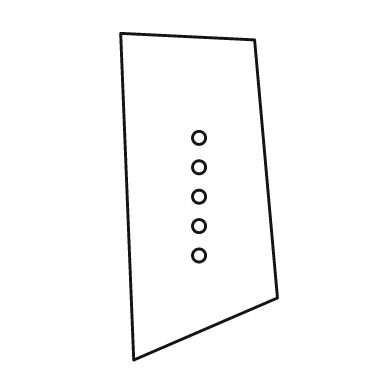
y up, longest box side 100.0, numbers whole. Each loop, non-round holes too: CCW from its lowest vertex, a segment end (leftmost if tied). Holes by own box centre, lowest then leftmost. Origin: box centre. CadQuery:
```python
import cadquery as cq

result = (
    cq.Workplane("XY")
    .moveTo(-20.0, -50.0)
    .lineTo(24.0, -31.0)
    .lineTo(17.0, 48.0)
    .lineTo(-24.0, 50.0)
    .close()
    .moveTo(0.0, -18.0)
    .circle(2.0)
    .moveTo(0.0, -9.0)
    .circle(2.0)
    .moveTo(0.0, 0.0)
    .circle(2.0)
    .moveTo(0.0, 9.0)
    .circle(2.0)
    .moveTo(0.0, 18.0)
    .circle(2.0)
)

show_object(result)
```